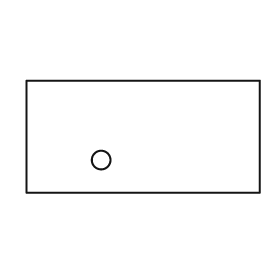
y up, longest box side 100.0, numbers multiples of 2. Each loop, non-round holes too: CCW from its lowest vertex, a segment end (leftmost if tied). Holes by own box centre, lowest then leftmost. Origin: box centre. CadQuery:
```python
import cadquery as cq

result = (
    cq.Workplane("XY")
    .moveTo(-50.0, -24.0)
    .lineTo(50.0, -24.0)
    .lineTo(50.0, 24.0)
    .lineTo(-50.0, 24.0)
    .close()
    .moveTo(-18.0, -10.0)
    .circle(4.0)
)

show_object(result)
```